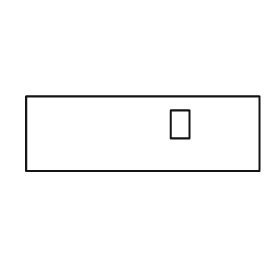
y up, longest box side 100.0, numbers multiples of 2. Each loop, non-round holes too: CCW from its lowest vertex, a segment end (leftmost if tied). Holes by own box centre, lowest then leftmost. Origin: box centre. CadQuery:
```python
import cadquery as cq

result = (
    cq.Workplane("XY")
    .moveTo(-50.0, -16.0)
    .lineTo(50.0, -16.0)
    .lineTo(50.0, 16.0)
    .lineTo(-50.0, 16.0)
    .close()
    .moveTo(12.0, -2.0)
    .lineTo(20.0, -2.0)
    .lineTo(20.0, 10.0)
    .lineTo(12.0, 10.0)
    .close()
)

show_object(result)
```